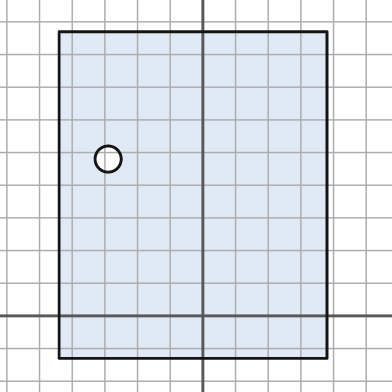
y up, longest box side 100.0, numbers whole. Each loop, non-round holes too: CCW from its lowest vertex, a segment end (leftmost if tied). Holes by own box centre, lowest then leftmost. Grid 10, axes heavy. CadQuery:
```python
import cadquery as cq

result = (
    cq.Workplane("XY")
    .moveTo(-44.0, -13.0)
    .lineTo(38.0, -13.0)
    .lineTo(38.0, 87.0)
    .lineTo(-44.0, 87.0)
    .close()
    .moveTo(-29.0, 48.0)
    .circle(4.0)
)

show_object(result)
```